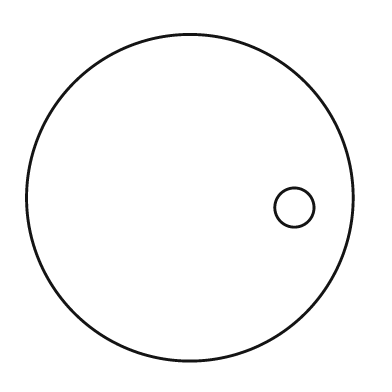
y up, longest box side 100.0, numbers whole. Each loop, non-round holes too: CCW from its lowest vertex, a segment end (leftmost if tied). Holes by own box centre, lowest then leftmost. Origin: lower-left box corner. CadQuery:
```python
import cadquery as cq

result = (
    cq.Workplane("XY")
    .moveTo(50.0, 50.0)
    .circle(50.0)
    .moveTo(82.0, 47.0)
    .circle(6.0)
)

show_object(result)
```